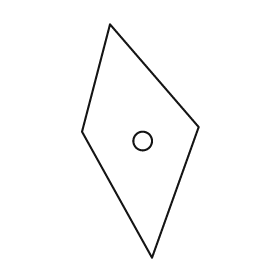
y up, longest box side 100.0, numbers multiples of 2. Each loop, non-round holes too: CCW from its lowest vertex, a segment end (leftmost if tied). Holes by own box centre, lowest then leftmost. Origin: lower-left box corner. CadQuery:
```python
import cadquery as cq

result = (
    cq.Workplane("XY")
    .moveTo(30.0, 0.0)
    .lineTo(50.0, 56.0)
    .lineTo(12.0, 100.0)
    .lineTo(0.0, 54.0)
    .close()
    .moveTo(26.0, 50.0)
    .circle(4.0)
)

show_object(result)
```